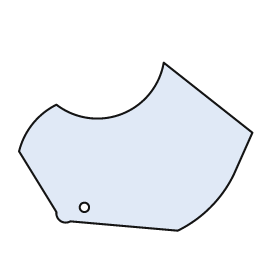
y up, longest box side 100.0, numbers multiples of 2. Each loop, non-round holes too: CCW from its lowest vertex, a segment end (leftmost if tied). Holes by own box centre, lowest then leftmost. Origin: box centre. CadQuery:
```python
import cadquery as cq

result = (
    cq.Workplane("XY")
    .moveTo(18.0, -36.0)
    .threePointArc((32.0, -26.0), (42.0, -12.0))
    .lineTo(50.0, 6.0)
    .lineTo(12.0, 36.0)
    .threePointArc((-6.0, 14.0), (-34.0, 18.0))
    .threePointArc((-44.0, 10.0), (-50.0, -2.0))
    .lineTo(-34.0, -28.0)
    .threePointArc((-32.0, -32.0), (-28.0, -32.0))
    .close()
    .moveTo(-22.0, -26.0)
    .circle(2.0)
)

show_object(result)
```